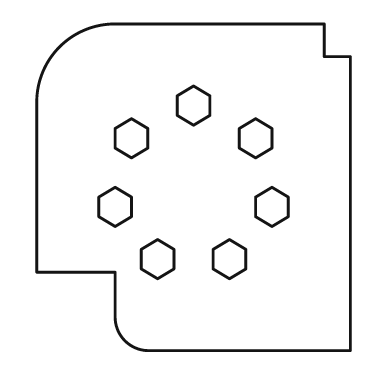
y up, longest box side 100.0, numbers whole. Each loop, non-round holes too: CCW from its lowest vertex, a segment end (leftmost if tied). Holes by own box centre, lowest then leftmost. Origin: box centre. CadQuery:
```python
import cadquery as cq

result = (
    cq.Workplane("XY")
    .moveTo(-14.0, -50.0)
    .lineTo(48.0, -50.0)
    .lineTo(48.0, 40.0)
    .lineTo(40.0, 40.0)
    .lineTo(40.0, 50.0)
    .lineTo(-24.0, 50.0)
    .threePointArc((-41.0, 43.0), (-48.0, 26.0))
    .lineTo(-48.0, -26.0)
    .lineTo(-24.0, -26.0)
    .lineTo(-24.0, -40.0)
    .threePointArc((-21.0, -47.0), (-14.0, -50.0))
    .close()
    .moveTo(-11.0, -28.0)
    .lineTo(-6.0, -25.0)
    .lineTo(-6.0, -19.0)
    .lineTo(-11.0, -16.0)
    .lineTo(-16.0, -19.0)
    .lineTo(-16.0, -25.0)
    .close()
    .moveTo(11.0, -28.0)
    .lineTo(16.0, -25.0)
    .lineTo(16.0, -19.0)
    .lineTo(11.0, -16.0)
    .lineTo(6.0, -19.0)
    .lineTo(6.0, -25.0)
    .close()
    .moveTo(-24.0, -12.0)
    .lineTo(-19.0, -9.0)
    .lineTo(-19.0, -3.0)
    .lineTo(-24.0, 0.0)
    .lineTo(-29.0, -3.0)
    .lineTo(-29.0, -9.0)
    .close()
    .moveTo(24.0, -12.0)
    .lineTo(29.0, -9.0)
    .lineTo(29.0, -3.0)
    .lineTo(24.0, 0.0)
    .lineTo(19.0, -3.0)
    .lineTo(19.0, -9.0)
    .close()
    .moveTo(-19.0, 9.0)
    .lineTo(-14.0, 12.0)
    .lineTo(-14.0, 18.0)
    .lineTo(-19.0, 21.0)
    .lineTo(-24.0, 18.0)
    .lineTo(-24.0, 12.0)
    .close()
    .moveTo(19.0, 9.0)
    .lineTo(24.0, 12.0)
    .lineTo(24.0, 18.0)
    .lineTo(19.0, 21.0)
    .lineTo(14.0, 18.0)
    .lineTo(14.0, 12.0)
    .close()
    .moveTo(0.0, 19.0)
    .lineTo(5.0, 22.0)
    .lineTo(5.0, 28.0)
    .lineTo(0.0, 31.0)
    .lineTo(-5.0, 28.0)
    .lineTo(-5.0, 22.0)
    .close()
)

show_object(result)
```